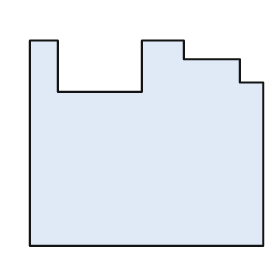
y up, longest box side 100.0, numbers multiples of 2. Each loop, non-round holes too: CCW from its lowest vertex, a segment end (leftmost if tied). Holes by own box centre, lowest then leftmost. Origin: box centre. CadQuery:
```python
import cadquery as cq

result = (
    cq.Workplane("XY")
    .moveTo(-50.0, -44.0)
    .lineTo(50.0, -44.0)
    .lineTo(50.0, 26.0)
    .lineTo(40.0, 26.0)
    .lineTo(40.0, 36.0)
    .lineTo(16.0, 36.0)
    .lineTo(16.0, 44.0)
    .lineTo(-2.0, 44.0)
    .lineTo(-2.0, 22.0)
    .lineTo(-38.0, 22.0)
    .lineTo(-38.0, 44.0)
    .lineTo(-50.0, 44.0)
    .close()
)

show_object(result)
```